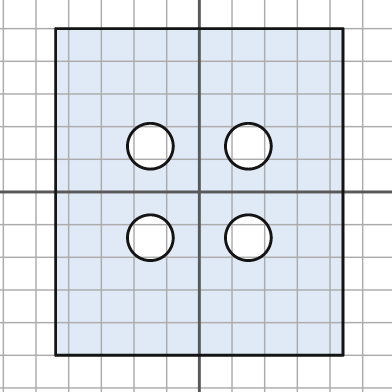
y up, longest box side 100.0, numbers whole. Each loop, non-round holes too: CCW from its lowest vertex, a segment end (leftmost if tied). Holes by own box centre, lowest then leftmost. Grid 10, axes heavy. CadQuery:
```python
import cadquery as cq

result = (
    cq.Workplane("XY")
    .moveTo(-44.0, -50.0)
    .lineTo(44.0, -50.0)
    .lineTo(44.0, 50.0)
    .lineTo(-44.0, 50.0)
    .close()
    .moveTo(-15.0, -14.0)
    .circle(7.0)
    .moveTo(15.0, -14.0)
    .circle(7.0)
    .moveTo(-15.0, 14.0)
    .circle(7.0)
    .moveTo(15.0, 14.0)
    .circle(7.0)
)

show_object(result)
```